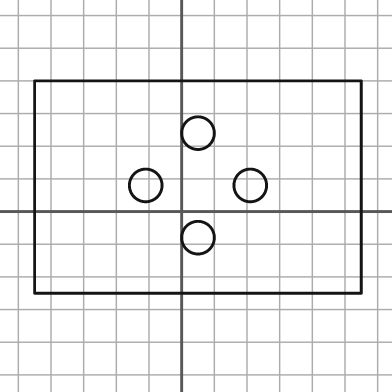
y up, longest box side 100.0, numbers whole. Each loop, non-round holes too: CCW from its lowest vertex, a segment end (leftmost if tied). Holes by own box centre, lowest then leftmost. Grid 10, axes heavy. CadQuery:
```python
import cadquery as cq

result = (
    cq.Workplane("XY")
    .moveTo(-45.0, -25.0)
    .lineTo(55.0, -25.0)
    .lineTo(55.0, 40.0)
    .lineTo(-45.0, 40.0)
    .close()
    .moveTo(5.0, -8.0)
    .circle(5.0)
    .moveTo(-11.0, 8.0)
    .circle(5.0)
    .moveTo(21.0, 8.0)
    .circle(5.0)
    .moveTo(5.0, 24.0)
    .circle(5.0)
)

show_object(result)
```